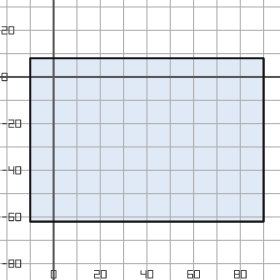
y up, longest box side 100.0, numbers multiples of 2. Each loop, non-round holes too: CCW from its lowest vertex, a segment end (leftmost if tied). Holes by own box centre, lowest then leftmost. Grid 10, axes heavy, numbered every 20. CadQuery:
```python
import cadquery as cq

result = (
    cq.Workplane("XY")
    .moveTo(-10.0, -62.0)
    .lineTo(90.0, -62.0)
    .lineTo(90.0, 8.0)
    .lineTo(-10.0, 8.0)
    .close()
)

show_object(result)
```